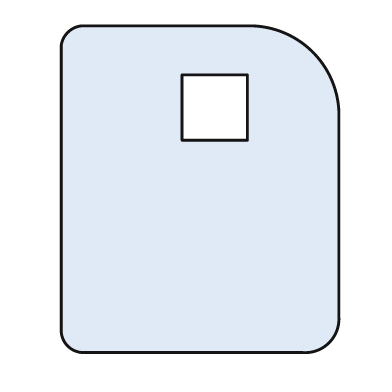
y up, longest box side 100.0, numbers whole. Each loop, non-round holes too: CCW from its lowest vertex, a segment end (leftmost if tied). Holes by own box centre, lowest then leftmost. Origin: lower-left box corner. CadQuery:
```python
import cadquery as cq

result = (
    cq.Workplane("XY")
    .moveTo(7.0, 0.0)
    .lineTo(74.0, 0.0)
    .threePointArc((82.0, 3.0), (85.0, 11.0))
    .lineTo(85.0, 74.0)
    .threePointArc((77.0, 92.0), (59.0, 100.0))
    .lineTo(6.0, 100.0)
    .threePointArc((2.0, 98.0), (0.0, 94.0))
    .lineTo(0.0, 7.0)
    .threePointArc((2.0, 2.0), (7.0, 0.0))
    .close()
    .moveTo(37.0, 65.0)
    .lineTo(57.0, 65.0)
    .lineTo(57.0, 85.0)
    .lineTo(37.0, 85.0)
    .close()
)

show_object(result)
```